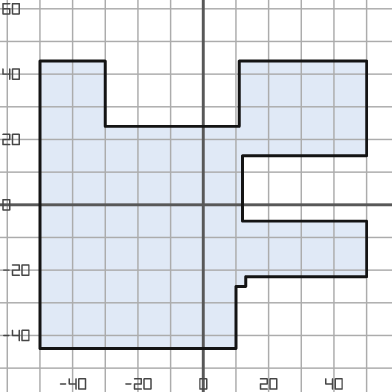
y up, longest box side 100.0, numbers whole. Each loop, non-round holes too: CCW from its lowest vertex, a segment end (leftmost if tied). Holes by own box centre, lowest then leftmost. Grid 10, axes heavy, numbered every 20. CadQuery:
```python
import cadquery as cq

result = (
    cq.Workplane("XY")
    .moveTo(-50.0, -44.0)
    .lineTo(10.0, -44.0)
    .lineTo(10.0, -25.0)
    .lineTo(13.0, -25.0)
    .lineTo(13.0, -22.0)
    .lineTo(50.0, -22.0)
    .lineTo(50.0, -5.0)
    .lineTo(12.0, -5.0)
    .lineTo(12.0, 15.0)
    .lineTo(50.0, 15.0)
    .lineTo(50.0, 44.0)
    .lineTo(11.0, 44.0)
    .lineTo(11.0, 24.0)
    .lineTo(-30.0, 24.0)
    .lineTo(-30.0, 44.0)
    .lineTo(-50.0, 44.0)
    .close()
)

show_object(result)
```